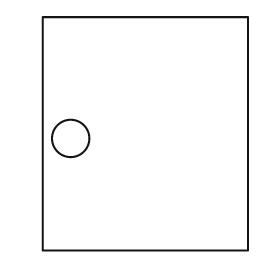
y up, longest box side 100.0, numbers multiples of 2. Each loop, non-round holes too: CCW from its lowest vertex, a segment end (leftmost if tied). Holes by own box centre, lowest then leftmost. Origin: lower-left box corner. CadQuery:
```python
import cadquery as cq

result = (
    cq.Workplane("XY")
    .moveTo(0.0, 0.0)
    .lineTo(88.0, 0.0)
    .lineTo(88.0, 100.0)
    .lineTo(0.0, 100.0)
    .close()
    .moveTo(12.0, 48.0)
    .circle(8.0)
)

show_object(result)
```